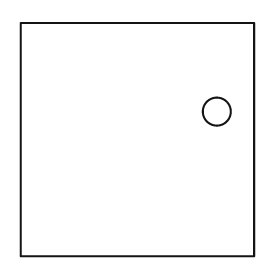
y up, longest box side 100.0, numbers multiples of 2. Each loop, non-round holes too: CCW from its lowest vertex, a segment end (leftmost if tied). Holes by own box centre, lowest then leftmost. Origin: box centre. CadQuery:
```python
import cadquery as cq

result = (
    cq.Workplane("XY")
    .moveTo(-50.0, -50.0)
    .lineTo(50.0, -50.0)
    .lineTo(50.0, 50.0)
    .lineTo(-50.0, 50.0)
    .close()
    .moveTo(34.0, 12.0)
    .circle(6.0)
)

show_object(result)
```